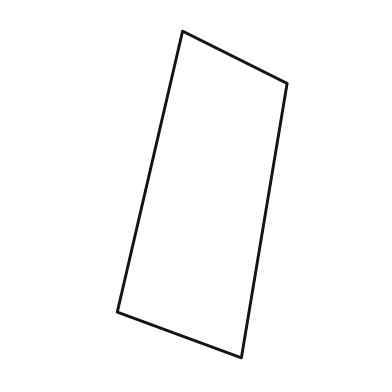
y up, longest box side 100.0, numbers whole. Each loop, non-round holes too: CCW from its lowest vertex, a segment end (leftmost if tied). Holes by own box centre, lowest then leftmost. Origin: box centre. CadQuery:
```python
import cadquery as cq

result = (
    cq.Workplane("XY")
    .moveTo(12.0, -50.0)
    .lineTo(26.0, 34.0)
    .lineTo(-6.0, 50.0)
    .lineTo(-26.0, -36.0)
    .close()
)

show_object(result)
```